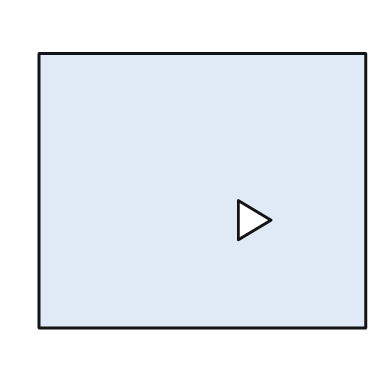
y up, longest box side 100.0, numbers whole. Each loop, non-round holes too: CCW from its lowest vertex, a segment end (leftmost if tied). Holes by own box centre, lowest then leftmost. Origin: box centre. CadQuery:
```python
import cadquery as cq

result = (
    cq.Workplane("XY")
    .moveTo(-50.0, -42.0)
    .lineTo(50.0, -42.0)
    .lineTo(50.0, 42.0)
    .lineTo(-50.0, 42.0)
    .close()
    .moveTo(11.0, -15.0)
    .lineTo(21.0, -9.0)
    .lineTo(11.0, -3.0)
    .close()
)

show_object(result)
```